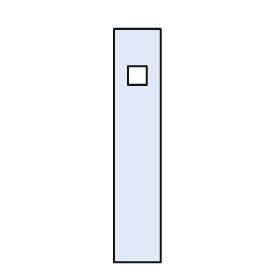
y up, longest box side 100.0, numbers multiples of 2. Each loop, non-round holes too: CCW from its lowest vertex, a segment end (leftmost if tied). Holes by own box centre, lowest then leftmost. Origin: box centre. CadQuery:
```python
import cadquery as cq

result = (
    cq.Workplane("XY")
    .moveTo(-10.0, -50.0)
    .lineTo(10.0, -50.0)
    .lineTo(10.0, 50.0)
    .lineTo(-10.0, 50.0)
    .close()
    .moveTo(-4.0, 26.0)
    .lineTo(4.0, 26.0)
    .lineTo(4.0, 34.0)
    .lineTo(-4.0, 34.0)
    .close()
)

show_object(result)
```